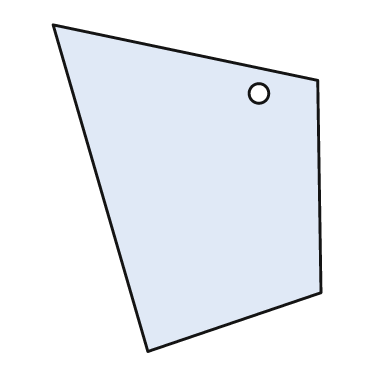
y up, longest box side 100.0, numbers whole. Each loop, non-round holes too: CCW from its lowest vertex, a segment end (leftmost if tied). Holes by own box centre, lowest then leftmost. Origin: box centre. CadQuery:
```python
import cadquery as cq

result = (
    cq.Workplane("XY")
    .moveTo(-12.0, -50.0)
    .lineTo(41.0, -32.0)
    .lineTo(40.0, 33.0)
    .lineTo(-41.0, 50.0)
    .close()
    .moveTo(22.0, 29.0)
    .circle(3.0)
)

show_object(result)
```